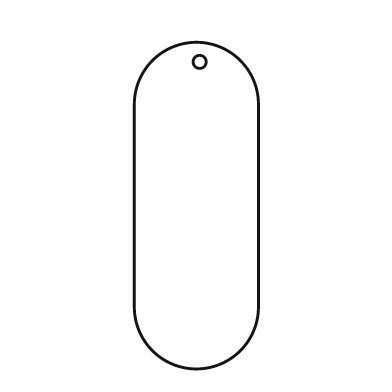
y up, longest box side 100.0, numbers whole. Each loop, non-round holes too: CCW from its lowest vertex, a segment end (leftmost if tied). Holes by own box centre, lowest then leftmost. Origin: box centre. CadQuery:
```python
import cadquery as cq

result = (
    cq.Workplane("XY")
    .moveTo(-19.0, -31.0)
    .threePointArc((0.0, -50.0), (19.0, -31.0))
    .lineTo(19.0, 31.0)
    .threePointArc((0.0, 50.0), (-19.0, 31.0))
    .close()
    .moveTo(1.0, 44.0)
    .circle(2.0)
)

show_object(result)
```